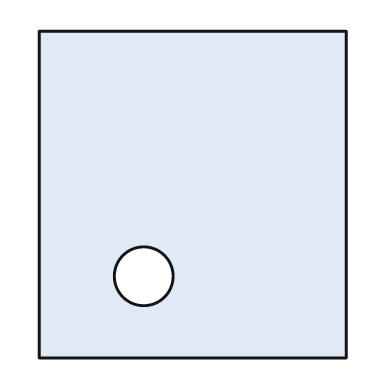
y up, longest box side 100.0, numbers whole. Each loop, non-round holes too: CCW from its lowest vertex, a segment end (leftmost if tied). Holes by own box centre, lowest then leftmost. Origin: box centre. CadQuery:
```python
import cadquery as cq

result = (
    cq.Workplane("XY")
    .moveTo(-47.0, -50.0)
    .lineTo(47.0, -50.0)
    .lineTo(47.0, 50.0)
    .lineTo(-47.0, 50.0)
    .close()
    .moveTo(-15.0, -25.0)
    .circle(9.0)
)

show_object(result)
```